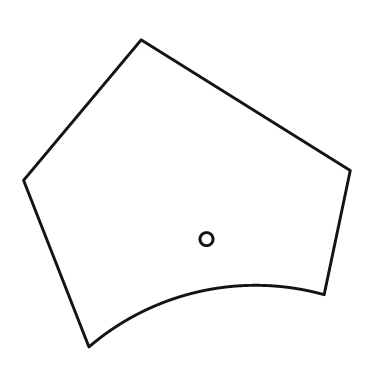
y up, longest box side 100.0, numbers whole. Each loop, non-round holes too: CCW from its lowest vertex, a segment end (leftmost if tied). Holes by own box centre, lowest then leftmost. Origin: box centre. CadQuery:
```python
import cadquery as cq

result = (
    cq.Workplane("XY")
    .moveTo(-30.0, -47.0)
    .threePointArc((4.0, -30.0), (42.0, -31.0))
    .lineTo(50.0, 7.0)
    .lineTo(-14.0, 47.0)
    .lineTo(-50.0, 4.0)
    .close()
    .moveTo(6.0, -14.0)
    .circle(2.0)
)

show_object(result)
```